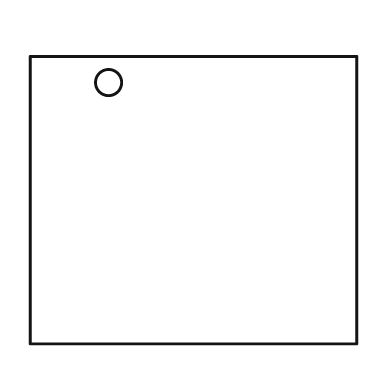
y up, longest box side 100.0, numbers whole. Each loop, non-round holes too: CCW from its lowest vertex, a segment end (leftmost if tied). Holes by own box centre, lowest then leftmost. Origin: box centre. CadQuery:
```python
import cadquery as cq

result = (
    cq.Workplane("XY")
    .moveTo(-50.0, -44.0)
    .lineTo(50.0, -44.0)
    .lineTo(50.0, 44.0)
    .lineTo(-50.0, 44.0)
    .close()
    .moveTo(-26.0, 36.0)
    .circle(4.0)
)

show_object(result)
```